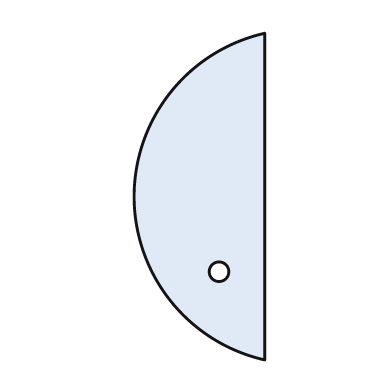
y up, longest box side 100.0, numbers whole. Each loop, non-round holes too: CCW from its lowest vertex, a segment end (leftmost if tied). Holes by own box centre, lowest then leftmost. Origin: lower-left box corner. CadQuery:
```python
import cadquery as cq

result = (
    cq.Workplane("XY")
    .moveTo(40.0, 0.0)
    .lineTo(40.0, 100.0)
    .threePointArc((0.0, 50.0), (40.0, 0.0))
    .close()
    .moveTo(26.0, 27.0)
    .circle(3.0)
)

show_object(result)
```